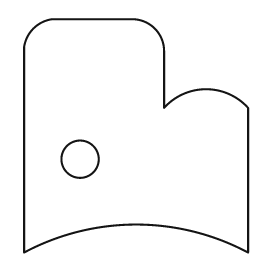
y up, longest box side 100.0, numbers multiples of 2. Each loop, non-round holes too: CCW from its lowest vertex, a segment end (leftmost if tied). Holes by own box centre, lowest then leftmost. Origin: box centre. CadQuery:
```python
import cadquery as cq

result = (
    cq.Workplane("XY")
    .moveTo(-48.0, -50.0)
    .threePointArc((0.0, -38.0), (48.0, -50.0))
    .lineTo(48.0, 12.0)
    .threePointArc((30.0, 20.0), (12.0, 12.0))
    .lineTo(12.0, 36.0)
    .threePointArc((8.0, 46.0), (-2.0, 50.0))
    .lineTo(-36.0, 50.0)
    .threePointArc((-44.0, 46.0), (-48.0, 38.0))
    .close()
    .moveTo(-24.0, -10.0)
    .circle(8.0)
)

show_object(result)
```